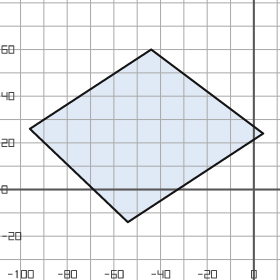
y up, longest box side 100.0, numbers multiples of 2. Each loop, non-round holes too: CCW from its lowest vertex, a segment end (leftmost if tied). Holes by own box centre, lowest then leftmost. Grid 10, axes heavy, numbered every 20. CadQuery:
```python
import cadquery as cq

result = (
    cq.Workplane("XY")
    .moveTo(-54.0, -14.0)
    .lineTo(4.0, 24.0)
    .lineTo(-44.0, 60.0)
    .lineTo(-96.0, 26.0)
    .close()
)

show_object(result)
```